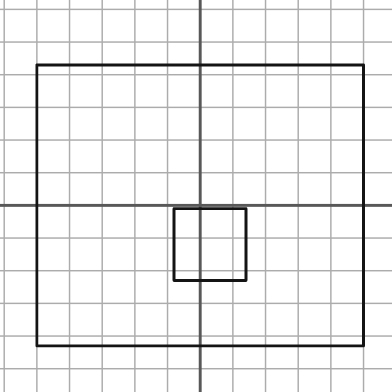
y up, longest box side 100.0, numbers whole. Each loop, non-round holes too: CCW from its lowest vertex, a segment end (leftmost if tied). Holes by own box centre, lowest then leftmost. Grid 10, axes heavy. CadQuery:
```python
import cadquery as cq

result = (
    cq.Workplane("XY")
    .moveTo(-50.0, -43.0)
    .lineTo(50.0, -43.0)
    .lineTo(50.0, 43.0)
    .lineTo(-50.0, 43.0)
    .close()
    .moveTo(-8.0, -23.0)
    .lineTo(14.0, -23.0)
    .lineTo(14.0, -1.0)
    .lineTo(-8.0, -1.0)
    .close()
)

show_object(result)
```